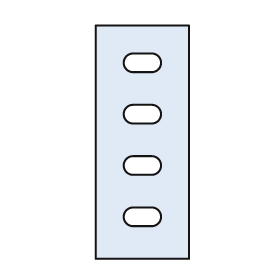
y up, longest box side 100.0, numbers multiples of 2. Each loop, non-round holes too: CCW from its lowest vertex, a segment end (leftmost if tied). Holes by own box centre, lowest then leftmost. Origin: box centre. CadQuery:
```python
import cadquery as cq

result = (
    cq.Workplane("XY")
    .moveTo(-20.0, -50.0)
    .lineTo(20.0, -50.0)
    .lineTo(20.0, 50.0)
    .lineTo(-20.0, 50.0)
    .close()
    .moveTo(-4.0, -36.0)
    .lineTo(4.0, -36.0)
    .threePointArc((8.0, -32.0), (4.0, -28.0))
    .lineTo(-4.0, -28.0)
    .threePointArc((-8.0, -32.0), (-4.0, -36.0))
    .close()
    .moveTo(-4.0, -14.0)
    .lineTo(4.0, -14.0)
    .threePointArc((8.0, -10.0), (4.0, -6.0))
    .lineTo(-4.0, -6.0)
    .threePointArc((-8.0, -10.0), (-4.0, -14.0))
    .close()
    .moveTo(-4.0, 8.0)
    .lineTo(4.0, 8.0)
    .threePointArc((8.0, 12.0), (4.0, 16.0))
    .lineTo(-4.0, 16.0)
    .threePointArc((-8.0, 12.0), (-4.0, 8.0))
    .close()
    .moveTo(-4.0, 30.0)
    .lineTo(4.0, 30.0)
    .threePointArc((8.0, 34.0), (4.0, 38.0))
    .lineTo(-4.0, 38.0)
    .threePointArc((-8.0, 34.0), (-4.0, 30.0))
    .close()
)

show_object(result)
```